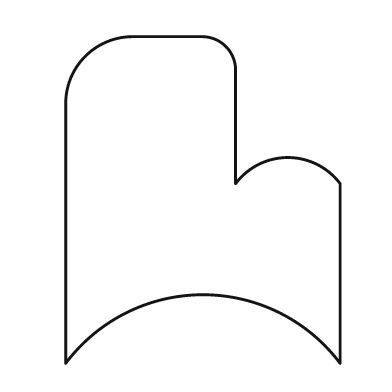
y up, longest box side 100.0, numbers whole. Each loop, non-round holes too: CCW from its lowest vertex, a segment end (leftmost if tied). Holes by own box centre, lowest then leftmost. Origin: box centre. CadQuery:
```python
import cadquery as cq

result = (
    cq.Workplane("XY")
    .moveTo(-42.0, -50.0)
    .threePointArc((0.0, -29.0), (42.0, -50.0))
    .lineTo(42.0, 5.0)
    .threePointArc((26.0, 13.0), (10.0, 5.0))
    .lineTo(10.0, 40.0)
    .threePointArc((7.0, 47.0), (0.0, 50.0))
    .lineTo(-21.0, 50.0)
    .threePointArc((-36.0, 44.0), (-42.0, 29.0))
    .close()
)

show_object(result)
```